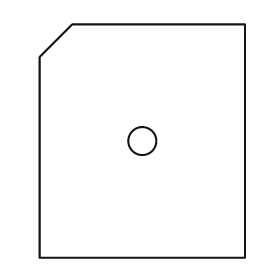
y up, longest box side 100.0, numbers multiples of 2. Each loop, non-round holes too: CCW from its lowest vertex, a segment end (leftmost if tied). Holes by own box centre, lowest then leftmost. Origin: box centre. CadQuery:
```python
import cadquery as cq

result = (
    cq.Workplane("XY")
    .moveTo(-44.0, -50.0)
    .lineTo(44.0, -50.0)
    .lineTo(44.0, 50.0)
    .lineTo(-30.0, 50.0)
    .lineTo(-44.0, 36.0)
    .close()
    .moveTo(0.0, 0.0)
    .circle(6.0)
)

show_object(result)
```